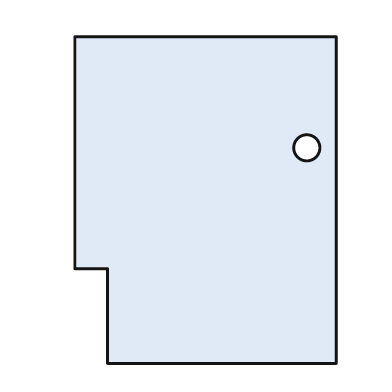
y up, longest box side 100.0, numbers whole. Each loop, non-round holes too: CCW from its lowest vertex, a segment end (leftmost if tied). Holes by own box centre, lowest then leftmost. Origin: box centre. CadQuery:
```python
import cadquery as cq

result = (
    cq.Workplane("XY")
    .moveTo(-30.0, -50.0)
    .lineTo(40.0, -50.0)
    .lineTo(40.0, 50.0)
    .lineTo(-40.0, 50.0)
    .lineTo(-40.0, -21.0)
    .lineTo(-30.0, -21.0)
    .close()
    .moveTo(31.0, 16.0)
    .circle(4.0)
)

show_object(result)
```